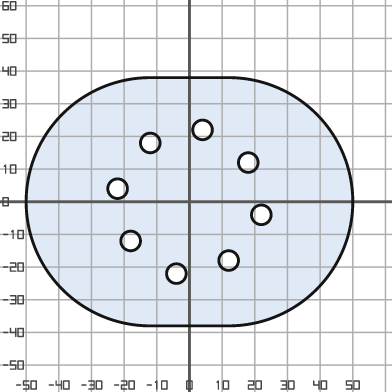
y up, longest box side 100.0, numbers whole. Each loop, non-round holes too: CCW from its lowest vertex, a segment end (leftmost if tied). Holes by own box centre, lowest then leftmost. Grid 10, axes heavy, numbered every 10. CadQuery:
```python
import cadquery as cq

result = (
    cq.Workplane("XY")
    .moveTo(-12.0, -38.0)
    .lineTo(12.0, -38.0)
    .threePointArc((50.0, 0.0), (12.0, 38.0))
    .lineTo(-12.0, 38.0)
    .threePointArc((-50.0, 0.0), (-12.0, -38.0))
    .close()
    .moveTo(-4.0, -22.0)
    .circle(3.0)
    .moveTo(12.0, -18.0)
    .circle(3.0)
    .moveTo(-18.0, -12.0)
    .circle(3.0)
    .moveTo(22.0, -4.0)
    .circle(3.0)
    .moveTo(-22.0, 4.0)
    .circle(3.0)
    .moveTo(18.0, 12.0)
    .circle(3.0)
    .moveTo(-12.0, 18.0)
    .circle(3.0)
    .moveTo(4.0, 22.0)
    .circle(3.0)
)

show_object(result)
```